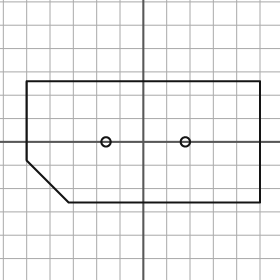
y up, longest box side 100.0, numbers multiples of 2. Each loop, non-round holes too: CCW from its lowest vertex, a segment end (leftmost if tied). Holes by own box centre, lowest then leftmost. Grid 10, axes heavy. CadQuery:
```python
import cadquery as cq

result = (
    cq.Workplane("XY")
    .moveTo(-32.0, -26.0)
    .lineTo(50.0, -26.0)
    .lineTo(50.0, 26.0)
    .lineTo(-50.0, 26.0)
    .lineTo(-50.0, -8.0)
    .close()
    .moveTo(-16.0, 0.0)
    .circle(2.0)
    .moveTo(18.0, 0.0)
    .circle(2.0)
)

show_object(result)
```